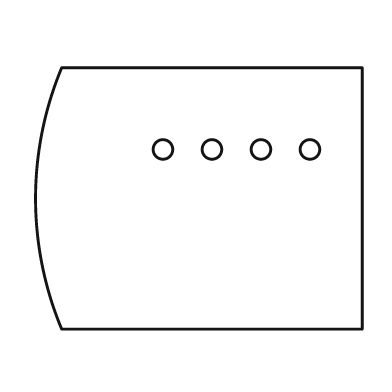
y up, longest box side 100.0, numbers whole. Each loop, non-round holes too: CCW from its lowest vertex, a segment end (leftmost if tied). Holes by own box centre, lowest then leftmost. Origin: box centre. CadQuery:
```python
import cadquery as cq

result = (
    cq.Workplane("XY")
    .moveTo(-42.0, -40.0)
    .lineTo(50.0, -40.0)
    .lineTo(50.0, 40.0)
    .lineTo(-42.0, 40.0)
    .threePointArc((-50.0, 0.0), (-42.0, -40.0))
    .close()
    .moveTo(-11.0, 15.0)
    .circle(3.0)
    .moveTo(4.0, 15.0)
    .circle(3.0)
    .moveTo(19.0, 15.0)
    .circle(3.0)
    .moveTo(34.0, 15.0)
    .circle(3.0)
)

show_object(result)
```